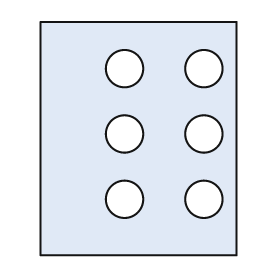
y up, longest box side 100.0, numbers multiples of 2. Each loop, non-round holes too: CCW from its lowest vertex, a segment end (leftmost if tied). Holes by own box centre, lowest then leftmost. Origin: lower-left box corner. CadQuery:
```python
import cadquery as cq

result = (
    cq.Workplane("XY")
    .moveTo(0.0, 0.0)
    .lineTo(84.0, 0.0)
    .lineTo(84.0, 100.0)
    .lineTo(0.0, 100.0)
    .close()
    .moveTo(36.0, 24.0)
    .circle(8.0)
    .moveTo(70.0, 24.0)
    .circle(8.0)
    .moveTo(36.0, 52.0)
    .circle(8.0)
    .moveTo(70.0, 52.0)
    .circle(8.0)
    .moveTo(36.0, 80.0)
    .circle(8.0)
    .moveTo(70.0, 80.0)
    .circle(8.0)
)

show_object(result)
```